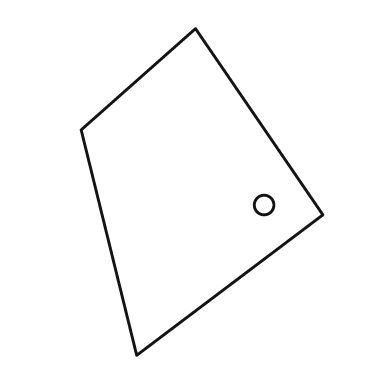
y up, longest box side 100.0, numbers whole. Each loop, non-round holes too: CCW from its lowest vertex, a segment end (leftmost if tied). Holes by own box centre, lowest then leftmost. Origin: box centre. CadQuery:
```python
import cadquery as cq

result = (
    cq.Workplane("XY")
    .moveTo(-20.0, -50.0)
    .lineTo(37.0, -7.0)
    .lineTo(-2.0, 50.0)
    .lineTo(-37.0, 19.0)
    .close()
    .moveTo(19.0, -4.0)
    .circle(3.0)
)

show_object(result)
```